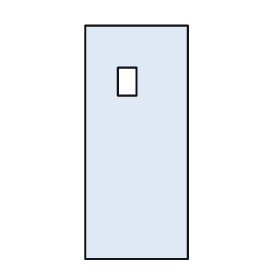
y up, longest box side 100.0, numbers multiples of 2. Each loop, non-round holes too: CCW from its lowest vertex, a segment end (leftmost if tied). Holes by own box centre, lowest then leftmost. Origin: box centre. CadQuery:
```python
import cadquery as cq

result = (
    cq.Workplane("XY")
    .moveTo(-22.0, -50.0)
    .lineTo(22.0, -50.0)
    .lineTo(22.0, 50.0)
    .lineTo(-22.0, 50.0)
    .close()
    .moveTo(-8.0, 20.0)
    .lineTo(0.0, 20.0)
    .lineTo(0.0, 32.0)
    .lineTo(-8.0, 32.0)
    .close()
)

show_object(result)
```